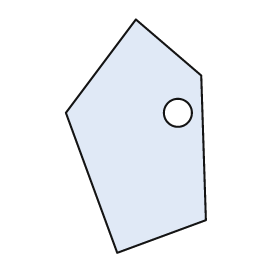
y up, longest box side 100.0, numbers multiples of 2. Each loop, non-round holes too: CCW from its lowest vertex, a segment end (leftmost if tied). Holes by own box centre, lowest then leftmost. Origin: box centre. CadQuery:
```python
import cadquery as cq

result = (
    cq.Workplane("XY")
    .moveTo(-8.0, -50.0)
    .lineTo(30.0, -36.0)
    .lineTo(28.0, 26.0)
    .lineTo(0.0, 50.0)
    .lineTo(-30.0, 10.0)
    .close()
    .moveTo(18.0, 10.0)
    .circle(6.0)
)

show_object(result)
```